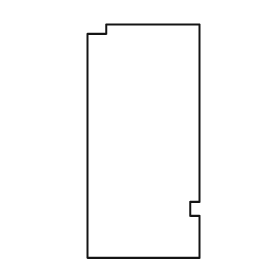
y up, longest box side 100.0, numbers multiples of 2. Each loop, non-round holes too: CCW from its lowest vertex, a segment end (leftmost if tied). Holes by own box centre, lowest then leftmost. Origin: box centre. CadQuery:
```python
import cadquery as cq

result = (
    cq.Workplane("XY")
    .moveTo(-24.0, -50.0)
    .lineTo(24.0, -50.0)
    .lineTo(24.0, -32.0)
    .lineTo(20.0, -32.0)
    .lineTo(20.0, -26.0)
    .lineTo(24.0, -26.0)
    .lineTo(24.0, 50.0)
    .lineTo(-16.0, 50.0)
    .lineTo(-16.0, 46.0)
    .lineTo(-24.0, 46.0)
    .close()
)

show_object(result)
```